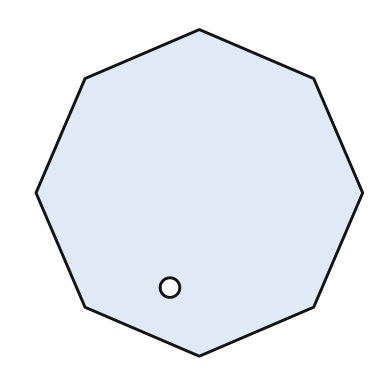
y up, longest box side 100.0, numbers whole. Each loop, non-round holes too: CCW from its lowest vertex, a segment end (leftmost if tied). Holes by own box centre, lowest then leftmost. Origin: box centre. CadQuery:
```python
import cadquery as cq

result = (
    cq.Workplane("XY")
    .moveTo(0.0, -50.0)
    .lineTo(35.0, -35.0)
    .lineTo(50.0, 0.0)
    .lineTo(35.0, 35.0)
    .lineTo(0.0, 50.0)
    .lineTo(-35.0, 35.0)
    .lineTo(-50.0, 0.0)
    .lineTo(-35.0, -35.0)
    .close()
    .moveTo(-9.0, -29.0)
    .circle(3.0)
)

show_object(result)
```